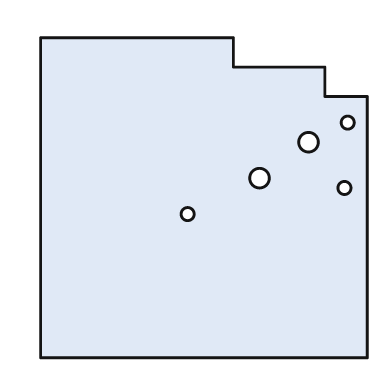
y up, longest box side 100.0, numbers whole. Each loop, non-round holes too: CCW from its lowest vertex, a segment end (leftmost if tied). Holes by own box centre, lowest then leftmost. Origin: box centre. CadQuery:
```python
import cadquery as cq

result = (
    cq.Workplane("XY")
    .moveTo(-50.0, -49.0)
    .lineTo(50.0, -49.0)
    .lineTo(50.0, 31.0)
    .lineTo(37.0, 31.0)
    .lineTo(37.0, 40.0)
    .lineTo(9.0, 40.0)
    .lineTo(9.0, 49.0)
    .lineTo(-50.0, 49.0)
    .close()
    .moveTo(-5.0, -5.0)
    .circle(2.0)
    .moveTo(43.0, 3.0)
    .circle(2.0)
    .moveTo(17.0, 6.0)
    .circle(3.0)
    .moveTo(32.0, 17.0)
    .circle(3.0)
    .moveTo(44.0, 23.0)
    .circle(2.0)
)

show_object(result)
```